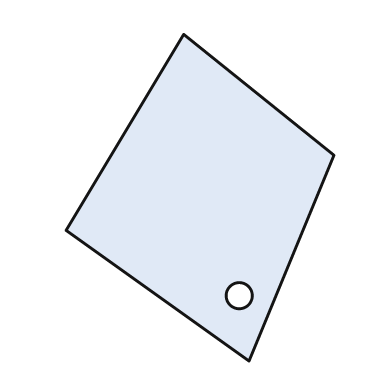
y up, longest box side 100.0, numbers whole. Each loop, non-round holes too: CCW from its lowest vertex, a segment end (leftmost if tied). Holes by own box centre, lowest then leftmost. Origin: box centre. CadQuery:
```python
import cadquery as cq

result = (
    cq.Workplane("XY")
    .moveTo(15.0, -50.0)
    .lineTo(41.0, 13.0)
    .lineTo(-5.0, 50.0)
    .lineTo(-41.0, -10.0)
    .close()
    .moveTo(12.0, -30.0)
    .circle(4.0)
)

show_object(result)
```